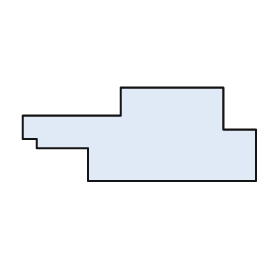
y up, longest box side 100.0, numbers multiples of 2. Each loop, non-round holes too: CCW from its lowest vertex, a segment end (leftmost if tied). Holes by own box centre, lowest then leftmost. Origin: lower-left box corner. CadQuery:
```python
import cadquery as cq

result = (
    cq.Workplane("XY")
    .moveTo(28.0, 0.0)
    .lineTo(100.0, 0.0)
    .lineTo(100.0, 22.0)
    .lineTo(86.0, 22.0)
    .lineTo(86.0, 40.0)
    .lineTo(42.0, 40.0)
    .lineTo(42.0, 28.0)
    .lineTo(0.0, 28.0)
    .lineTo(0.0, 18.0)
    .lineTo(6.0, 18.0)
    .lineTo(6.0, 14.0)
    .lineTo(28.0, 14.0)
    .close()
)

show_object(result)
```